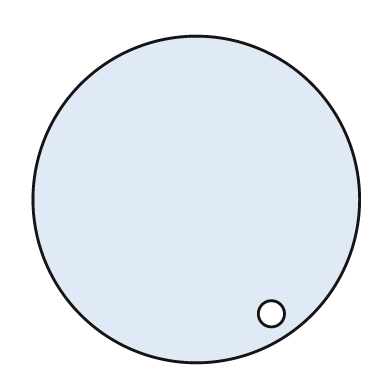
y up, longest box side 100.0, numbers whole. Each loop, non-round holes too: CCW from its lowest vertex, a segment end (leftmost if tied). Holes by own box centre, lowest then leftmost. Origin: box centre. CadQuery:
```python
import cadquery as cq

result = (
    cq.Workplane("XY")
    .moveTo(0.0, 0.0)
    .circle(50.0)
    .moveTo(23.0, -35.0)
    .circle(4.0)
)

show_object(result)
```